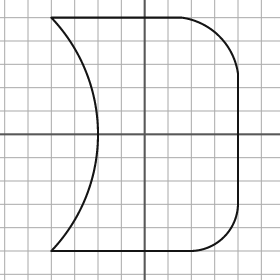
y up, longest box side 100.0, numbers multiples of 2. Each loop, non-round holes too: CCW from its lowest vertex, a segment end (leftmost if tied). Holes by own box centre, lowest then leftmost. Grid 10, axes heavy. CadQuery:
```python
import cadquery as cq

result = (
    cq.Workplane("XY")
    .moveTo(-40.0, -50.0)
    .lineTo(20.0, -50.0)
    .threePointArc((34.0, -44.0), (40.0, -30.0))
    .lineTo(40.0, 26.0)
    .threePointArc((32.0, 42.0), (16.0, 50.0))
    .lineTo(-40.0, 50.0)
    .threePointArc((-20.0, 0.0), (-40.0, -50.0))
    .close()
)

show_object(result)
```